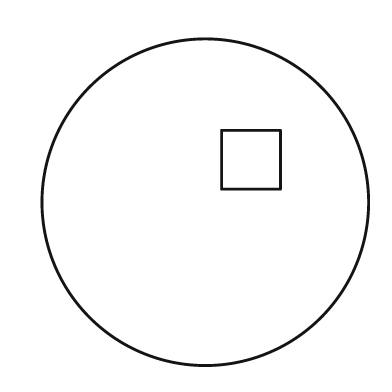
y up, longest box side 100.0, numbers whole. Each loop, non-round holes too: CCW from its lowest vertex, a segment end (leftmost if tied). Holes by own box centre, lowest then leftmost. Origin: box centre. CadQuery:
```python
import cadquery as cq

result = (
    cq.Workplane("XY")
    .moveTo(0.0, 0.0)
    .circle(50.0)
    .moveTo(5.0, 4.0)
    .lineTo(23.0, 4.0)
    .lineTo(23.0, 22.0)
    .lineTo(5.0, 22.0)
    .close()
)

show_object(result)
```